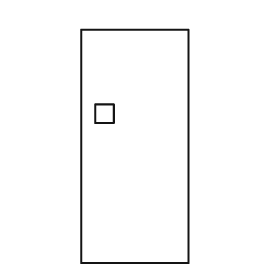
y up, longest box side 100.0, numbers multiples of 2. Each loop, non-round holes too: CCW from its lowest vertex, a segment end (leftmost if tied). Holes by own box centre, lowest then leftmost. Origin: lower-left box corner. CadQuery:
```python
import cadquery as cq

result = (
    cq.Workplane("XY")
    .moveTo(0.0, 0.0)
    .lineTo(46.0, 0.0)
    .lineTo(46.0, 100.0)
    .lineTo(0.0, 100.0)
    .close()
    .moveTo(6.0, 60.0)
    .lineTo(14.0, 60.0)
    .lineTo(14.0, 68.0)
    .lineTo(6.0, 68.0)
    .close()
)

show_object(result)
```